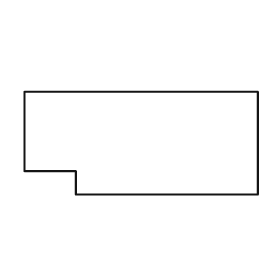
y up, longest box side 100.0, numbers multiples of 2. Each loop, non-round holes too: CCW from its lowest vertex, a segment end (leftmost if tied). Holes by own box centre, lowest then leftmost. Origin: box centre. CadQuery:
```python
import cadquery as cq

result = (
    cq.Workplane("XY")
    .moveTo(-28.0, -22.0)
    .lineTo(50.0, -22.0)
    .lineTo(50.0, 22.0)
    .lineTo(-50.0, 22.0)
    .lineTo(-50.0, -12.0)
    .lineTo(-28.0, -12.0)
    .close()
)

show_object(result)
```